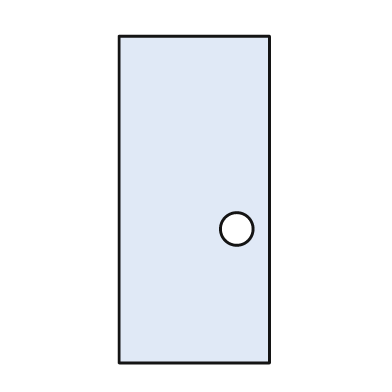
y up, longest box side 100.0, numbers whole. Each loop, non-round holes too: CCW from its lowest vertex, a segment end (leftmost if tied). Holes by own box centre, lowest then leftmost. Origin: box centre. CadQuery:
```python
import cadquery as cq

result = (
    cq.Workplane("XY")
    .moveTo(-23.0, -50.0)
    .lineTo(23.0, -50.0)
    .lineTo(23.0, 50.0)
    .lineTo(-23.0, 50.0)
    .close()
    .moveTo(13.0, -9.0)
    .circle(5.0)
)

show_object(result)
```